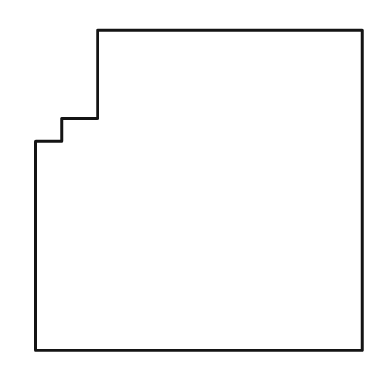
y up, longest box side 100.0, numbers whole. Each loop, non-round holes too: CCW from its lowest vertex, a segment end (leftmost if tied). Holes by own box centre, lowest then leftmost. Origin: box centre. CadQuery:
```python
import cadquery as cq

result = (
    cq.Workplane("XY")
    .moveTo(-50.0, -49.0)
    .lineTo(50.0, -49.0)
    .lineTo(50.0, 49.0)
    .lineTo(-31.0, 49.0)
    .lineTo(-31.0, 22.0)
    .lineTo(-42.0, 22.0)
    .lineTo(-42.0, 15.0)
    .lineTo(-50.0, 15.0)
    .close()
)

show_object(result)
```